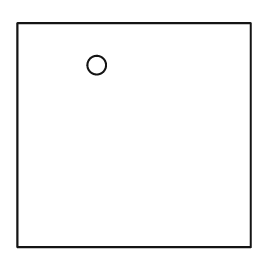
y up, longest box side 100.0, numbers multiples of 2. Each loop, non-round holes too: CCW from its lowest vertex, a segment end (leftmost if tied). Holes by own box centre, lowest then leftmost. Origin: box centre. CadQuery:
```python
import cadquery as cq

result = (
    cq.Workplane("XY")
    .moveTo(-50.0, -48.0)
    .lineTo(50.0, -48.0)
    .lineTo(50.0, 48.0)
    .lineTo(-50.0, 48.0)
    .close()
    .moveTo(-16.0, 30.0)
    .circle(4.0)
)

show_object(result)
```